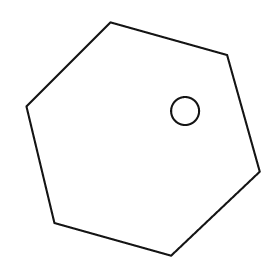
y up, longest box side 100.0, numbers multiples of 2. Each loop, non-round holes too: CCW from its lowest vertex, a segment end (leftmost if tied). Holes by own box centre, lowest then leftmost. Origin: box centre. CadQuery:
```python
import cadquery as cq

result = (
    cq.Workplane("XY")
    .moveTo(12.0, -50.0)
    .lineTo(50.0, -14.0)
    .lineTo(36.0, 36.0)
    .lineTo(-14.0, 50.0)
    .lineTo(-50.0, 14.0)
    .lineTo(-38.0, -36.0)
    .close()
    .moveTo(18.0, 12.0)
    .circle(6.0)
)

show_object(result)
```